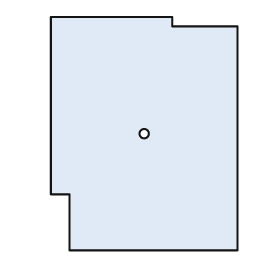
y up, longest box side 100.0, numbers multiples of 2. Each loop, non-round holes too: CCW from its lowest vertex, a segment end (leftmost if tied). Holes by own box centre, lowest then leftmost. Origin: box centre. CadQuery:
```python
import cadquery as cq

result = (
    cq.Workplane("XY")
    .moveTo(-32.0, -50.0)
    .lineTo(40.0, -50.0)
    .lineTo(40.0, 46.0)
    .lineTo(12.0, 46.0)
    .lineTo(12.0, 50.0)
    .lineTo(-40.0, 50.0)
    .lineTo(-40.0, -26.0)
    .lineTo(-32.0, -26.0)
    .close()
    .moveTo(0.0, 0.0)
    .circle(2.0)
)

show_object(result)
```